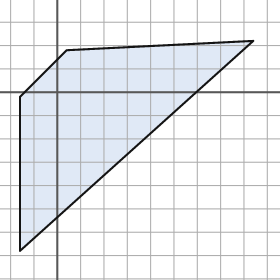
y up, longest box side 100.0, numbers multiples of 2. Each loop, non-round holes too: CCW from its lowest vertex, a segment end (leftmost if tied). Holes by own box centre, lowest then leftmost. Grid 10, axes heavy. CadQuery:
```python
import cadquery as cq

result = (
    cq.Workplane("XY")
    .moveTo(-16.0, -68.0)
    .lineTo(84.0, 22.0)
    .lineTo(4.0, 18.0)
    .lineTo(-16.0, -2.0)
    .close()
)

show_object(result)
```